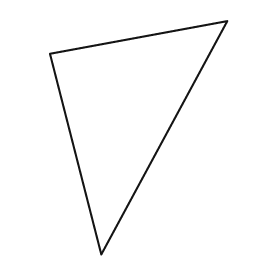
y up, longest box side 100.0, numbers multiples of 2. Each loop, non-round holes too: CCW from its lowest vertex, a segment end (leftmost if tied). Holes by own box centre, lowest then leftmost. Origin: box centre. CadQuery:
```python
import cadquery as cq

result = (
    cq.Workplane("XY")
    .moveTo(-16.0, -50.0)
    .lineTo(38.0, 50.0)
    .lineTo(-38.0, 36.0)
    .close()
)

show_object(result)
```